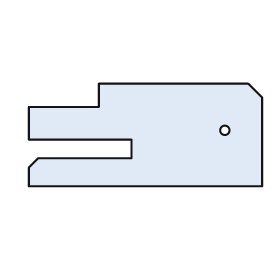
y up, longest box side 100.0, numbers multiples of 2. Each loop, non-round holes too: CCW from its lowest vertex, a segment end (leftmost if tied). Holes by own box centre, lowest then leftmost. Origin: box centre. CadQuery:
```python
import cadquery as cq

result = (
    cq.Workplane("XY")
    .moveTo(-50.0, -22.0)
    .lineTo(50.0, -22.0)
    .lineTo(50.0, 16.0)
    .lineTo(44.0, 22.0)
    .lineTo(-20.0, 22.0)
    .lineTo(-20.0, 12.0)
    .lineTo(-50.0, 12.0)
    .lineTo(-50.0, -2.0)
    .lineTo(-6.0, -2.0)
    .lineTo(-6.0, -10.0)
    .lineTo(-46.0, -10.0)
    .lineTo(-50.0, -14.0)
    .close()
    .moveTo(34.0, 2.0)
    .circle(2.0)
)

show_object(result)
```